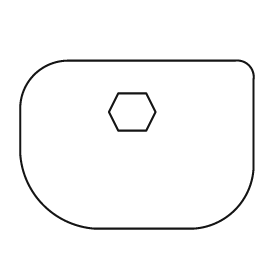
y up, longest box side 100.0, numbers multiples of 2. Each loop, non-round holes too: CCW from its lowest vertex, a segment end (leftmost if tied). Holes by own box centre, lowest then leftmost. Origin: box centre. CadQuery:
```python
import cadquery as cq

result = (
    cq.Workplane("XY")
    .moveTo(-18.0, -36.0)
    .lineTo(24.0, -36.0)
    .threePointArc((42.0, -28.0), (50.0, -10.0))
    .lineTo(50.0, 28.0)
    .threePointArc((48.0, 34.0), (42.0, 36.0))
    .lineTo(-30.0, 36.0)
    .threePointArc((-44.0, 30.0), (-50.0, 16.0))
    .lineTo(-50.0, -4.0)
    .threePointArc((-40.0, -26.0), (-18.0, -36.0))
    .close()
    .moveTo(-8.0, 6.0)
    .lineTo(4.0, 6.0)
    .lineTo(8.0, 14.0)
    .lineTo(4.0, 22.0)
    .lineTo(-8.0, 22.0)
    .lineTo(-12.0, 14.0)
    .close()
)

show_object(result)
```